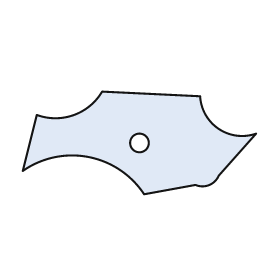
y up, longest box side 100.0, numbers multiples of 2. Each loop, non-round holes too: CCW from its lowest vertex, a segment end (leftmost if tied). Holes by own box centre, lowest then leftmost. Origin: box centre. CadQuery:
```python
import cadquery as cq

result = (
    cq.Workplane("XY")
    .moveTo(2.0, -22.0)
    .lineTo(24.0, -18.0)
    .threePointArc((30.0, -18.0), (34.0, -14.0))
    .lineTo(50.0, 4.0)
    .threePointArc((34.0, 6.0), (26.0, 20.0))
    .lineTo(-16.0, 22.0)
    .threePointArc((-28.0, 12.0), (-44.0, 12.0))
    .lineTo(-50.0, -12.0)
    .threePointArc((-22.0, -6.0), (2.0, -22.0))
    .close()
    .moveTo(0.0, 0.0)
    .circle(4.0)
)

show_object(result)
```